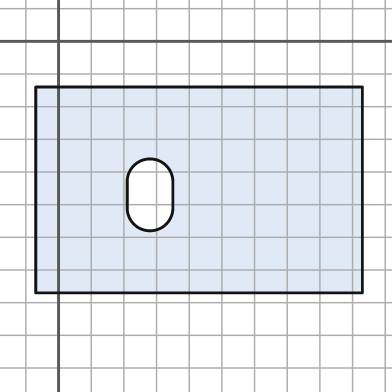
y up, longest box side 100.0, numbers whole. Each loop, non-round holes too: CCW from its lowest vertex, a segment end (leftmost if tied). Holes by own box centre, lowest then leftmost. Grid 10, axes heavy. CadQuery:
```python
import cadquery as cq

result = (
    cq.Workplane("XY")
    .moveTo(-7.0, -77.0)
    .lineTo(93.0, -77.0)
    .lineTo(93.0, -14.0)
    .lineTo(-7.0, -14.0)
    .close()
    .moveTo(21.0, -51.0)
    .threePointArc((28.0, -58.0), (35.0, -51.0))
    .lineTo(35.0, -43.0)
    .threePointArc((28.0, -36.0), (21.0, -43.0))
    .close()
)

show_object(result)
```